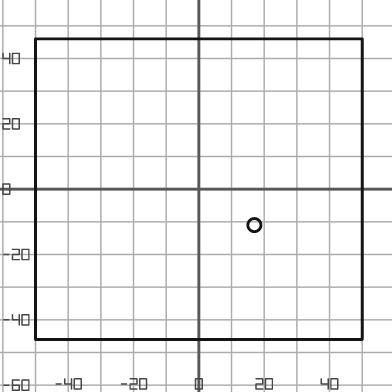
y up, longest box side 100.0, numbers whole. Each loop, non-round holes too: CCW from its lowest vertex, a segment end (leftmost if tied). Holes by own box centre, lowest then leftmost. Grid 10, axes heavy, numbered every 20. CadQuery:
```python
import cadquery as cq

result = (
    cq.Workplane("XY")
    .moveTo(-50.0, -46.0)
    .lineTo(50.0, -46.0)
    .lineTo(50.0, 46.0)
    .lineTo(-50.0, 46.0)
    .close()
    .moveTo(17.0, -11.0)
    .circle(2.0)
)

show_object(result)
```